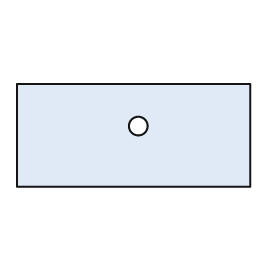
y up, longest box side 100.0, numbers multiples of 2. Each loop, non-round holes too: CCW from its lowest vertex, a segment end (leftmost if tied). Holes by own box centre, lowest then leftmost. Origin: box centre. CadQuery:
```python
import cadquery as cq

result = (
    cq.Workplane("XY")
    .moveTo(-50.0, -22.0)
    .lineTo(50.0, -22.0)
    .lineTo(50.0, 22.0)
    .lineTo(-50.0, 22.0)
    .close()
    .moveTo(2.0, 4.0)
    .circle(4.0)
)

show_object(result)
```